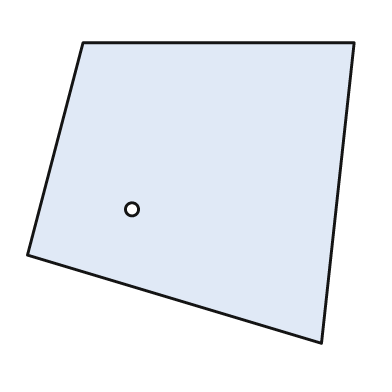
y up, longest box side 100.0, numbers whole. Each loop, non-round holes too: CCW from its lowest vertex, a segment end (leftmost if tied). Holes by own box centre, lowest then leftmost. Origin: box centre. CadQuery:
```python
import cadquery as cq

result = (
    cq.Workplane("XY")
    .moveTo(40.0, -46.0)
    .lineTo(50.0, 46.0)
    .lineTo(-33.0, 46.0)
    .lineTo(-50.0, -19.0)
    .close()
    .moveTo(-18.0, -5.0)
    .circle(2.0)
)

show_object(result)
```